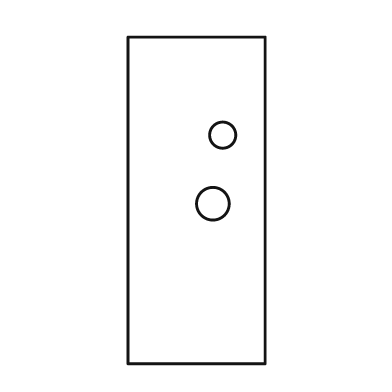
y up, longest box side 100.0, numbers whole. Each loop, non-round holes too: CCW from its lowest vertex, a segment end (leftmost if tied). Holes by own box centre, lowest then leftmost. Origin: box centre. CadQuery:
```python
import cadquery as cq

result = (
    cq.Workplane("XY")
    .moveTo(-21.0, -50.0)
    .lineTo(21.0, -50.0)
    .lineTo(21.0, 50.0)
    .lineTo(-21.0, 50.0)
    .close()
    .moveTo(5.0, -1.0)
    .circle(5.0)
    .moveTo(8.0, 20.0)
    .circle(4.0)
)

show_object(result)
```